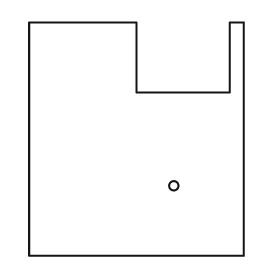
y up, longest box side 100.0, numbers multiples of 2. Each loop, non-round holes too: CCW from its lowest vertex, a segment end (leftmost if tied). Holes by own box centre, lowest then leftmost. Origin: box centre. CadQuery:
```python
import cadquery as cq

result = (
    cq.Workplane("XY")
    .moveTo(-46.0, -50.0)
    .lineTo(46.0, -50.0)
    .lineTo(46.0, 50.0)
    .lineTo(40.0, 50.0)
    .lineTo(40.0, 20.0)
    .lineTo(0.0, 20.0)
    .lineTo(0.0, 50.0)
    .lineTo(-46.0, 50.0)
    .close()
    .moveTo(16.0, -20.0)
    .circle(2.0)
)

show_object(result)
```